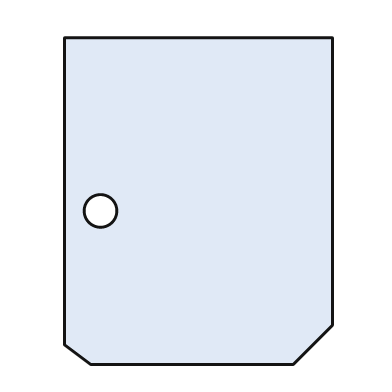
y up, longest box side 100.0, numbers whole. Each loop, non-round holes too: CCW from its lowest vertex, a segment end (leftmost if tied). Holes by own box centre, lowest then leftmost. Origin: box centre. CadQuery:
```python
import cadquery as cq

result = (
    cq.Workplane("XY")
    .moveTo(-33.0, -50.0)
    .lineTo(29.0, -50.0)
    .lineTo(41.0, -38.0)
    .lineTo(41.0, 50.0)
    .lineTo(-41.0, 50.0)
    .lineTo(-41.0, -44.0)
    .close()
    .moveTo(-30.0, -3.0)
    .circle(5.0)
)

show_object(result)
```